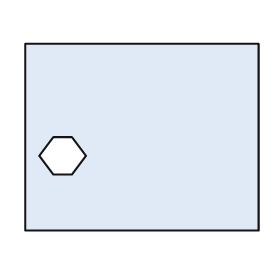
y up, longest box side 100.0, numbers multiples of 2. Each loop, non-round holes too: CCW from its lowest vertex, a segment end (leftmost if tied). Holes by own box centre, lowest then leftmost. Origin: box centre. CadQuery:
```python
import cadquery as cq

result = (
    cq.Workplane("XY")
    .moveTo(-50.0, -40.0)
    .lineTo(50.0, -40.0)
    .lineTo(50.0, 40.0)
    .lineTo(-50.0, 40.0)
    .close()
    .moveTo(-38.0, -16.0)
    .lineTo(-30.0, -16.0)
    .lineTo(-24.0, -8.0)
    .lineTo(-30.0, 0.0)
    .lineTo(-38.0, 0.0)
    .lineTo(-44.0, -8.0)
    .close()
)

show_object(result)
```